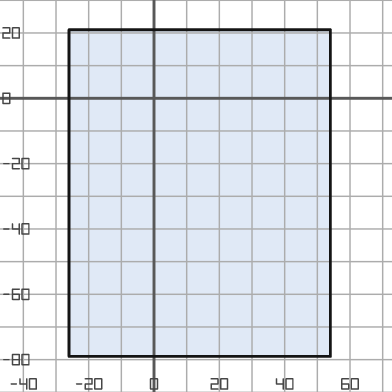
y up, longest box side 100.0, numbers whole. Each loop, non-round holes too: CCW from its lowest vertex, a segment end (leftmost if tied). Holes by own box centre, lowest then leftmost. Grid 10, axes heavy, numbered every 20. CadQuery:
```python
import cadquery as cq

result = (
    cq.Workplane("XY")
    .moveTo(-26.0, -79.0)
    .lineTo(54.0, -79.0)
    .lineTo(54.0, 21.0)
    .lineTo(-26.0, 21.0)
    .close()
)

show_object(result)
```